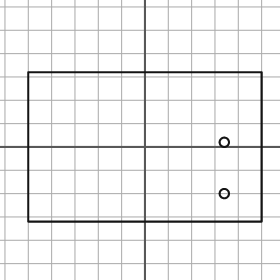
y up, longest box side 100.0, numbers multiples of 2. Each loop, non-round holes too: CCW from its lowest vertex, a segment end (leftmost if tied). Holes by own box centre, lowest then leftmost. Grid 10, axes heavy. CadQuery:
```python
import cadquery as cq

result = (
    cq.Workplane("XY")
    .moveTo(-50.0, -32.0)
    .lineTo(50.0, -32.0)
    .lineTo(50.0, 32.0)
    .lineTo(-50.0, 32.0)
    .close()
    .moveTo(34.0, -20.0)
    .circle(2.0)
    .moveTo(34.0, 2.0)
    .circle(2.0)
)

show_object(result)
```